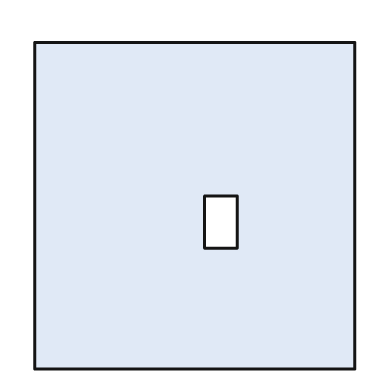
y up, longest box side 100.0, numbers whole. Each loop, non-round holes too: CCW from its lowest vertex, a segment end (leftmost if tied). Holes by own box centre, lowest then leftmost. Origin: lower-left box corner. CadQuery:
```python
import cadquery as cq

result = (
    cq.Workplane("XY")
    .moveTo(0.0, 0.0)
    .lineTo(98.0, 0.0)
    .lineTo(98.0, 100.0)
    .lineTo(0.0, 100.0)
    .close()
    .moveTo(52.0, 37.0)
    .lineTo(62.0, 37.0)
    .lineTo(62.0, 53.0)
    .lineTo(52.0, 53.0)
    .close()
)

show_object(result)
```